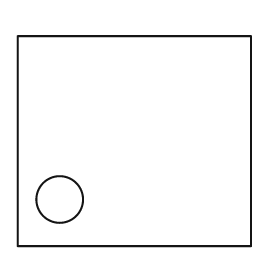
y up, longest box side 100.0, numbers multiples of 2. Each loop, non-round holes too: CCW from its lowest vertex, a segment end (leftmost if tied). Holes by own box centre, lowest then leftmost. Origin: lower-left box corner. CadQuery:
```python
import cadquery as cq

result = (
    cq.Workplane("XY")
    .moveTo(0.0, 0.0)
    .lineTo(100.0, 0.0)
    .lineTo(100.0, 90.0)
    .lineTo(0.0, 90.0)
    .close()
    .moveTo(18.0, 20.0)
    .circle(10.0)
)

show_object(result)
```